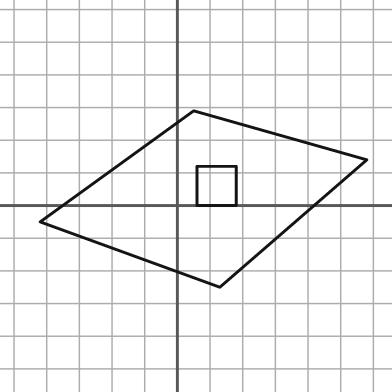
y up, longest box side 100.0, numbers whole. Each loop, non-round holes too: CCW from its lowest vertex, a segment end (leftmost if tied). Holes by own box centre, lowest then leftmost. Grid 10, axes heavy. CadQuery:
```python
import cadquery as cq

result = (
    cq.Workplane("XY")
    .moveTo(13.0, -25.0)
    .lineTo(58.0, 14.0)
    .lineTo(5.0, 29.0)
    .lineTo(-42.0, -5.0)
    .close()
    .moveTo(6.0, 0.0)
    .lineTo(18.0, 0.0)
    .lineTo(18.0, 12.0)
    .lineTo(6.0, 12.0)
    .close()
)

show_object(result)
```